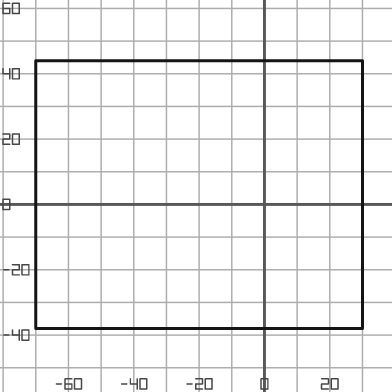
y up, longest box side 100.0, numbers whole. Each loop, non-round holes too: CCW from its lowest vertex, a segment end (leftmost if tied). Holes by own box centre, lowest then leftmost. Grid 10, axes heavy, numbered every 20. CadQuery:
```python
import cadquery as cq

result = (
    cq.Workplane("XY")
    .moveTo(-70.0, -38.0)
    .lineTo(30.0, -38.0)
    .lineTo(30.0, 44.0)
    .lineTo(-70.0, 44.0)
    .close()
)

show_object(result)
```